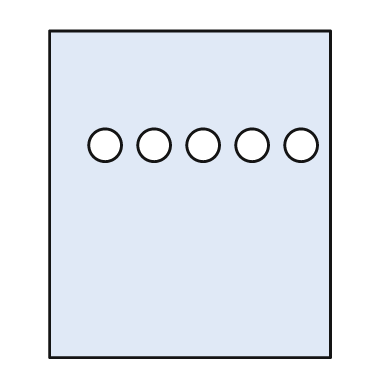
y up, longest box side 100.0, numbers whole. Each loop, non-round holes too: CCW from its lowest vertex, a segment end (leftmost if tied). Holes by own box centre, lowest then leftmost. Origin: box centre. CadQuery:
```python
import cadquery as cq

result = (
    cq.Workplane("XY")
    .moveTo(-43.0, -50.0)
    .lineTo(43.0, -50.0)
    .lineTo(43.0, 50.0)
    .lineTo(-43.0, 50.0)
    .close()
    .moveTo(-26.0, 15.0)
    .circle(5.0)
    .moveTo(-11.0, 15.0)
    .circle(5.0)
    .moveTo(4.0, 15.0)
    .circle(5.0)
    .moveTo(19.0, 15.0)
    .circle(5.0)
    .moveTo(34.0, 15.0)
    .circle(5.0)
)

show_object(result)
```